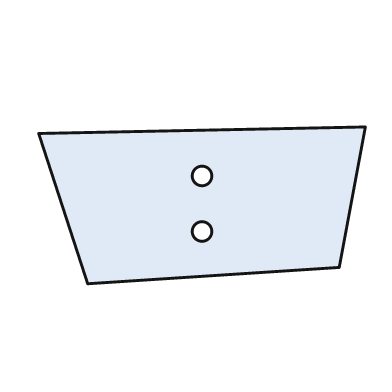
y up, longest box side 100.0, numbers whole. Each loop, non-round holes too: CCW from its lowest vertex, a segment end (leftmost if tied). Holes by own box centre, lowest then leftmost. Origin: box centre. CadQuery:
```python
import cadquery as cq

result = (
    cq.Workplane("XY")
    .moveTo(-35.0, -24.0)
    .lineTo(42.0, -19.0)
    .lineTo(50.0, 24.0)
    .lineTo(-50.0, 22.0)
    .close()
    .moveTo(0.0, -8.0)
    .circle(3.0)
    .moveTo(0.0, 9.0)
    .circle(3.0)
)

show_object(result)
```